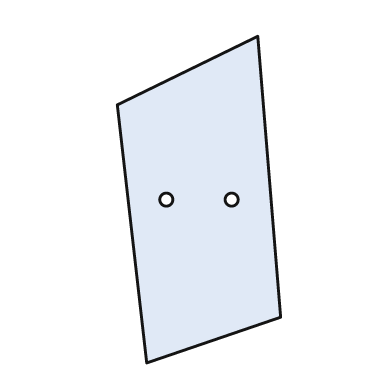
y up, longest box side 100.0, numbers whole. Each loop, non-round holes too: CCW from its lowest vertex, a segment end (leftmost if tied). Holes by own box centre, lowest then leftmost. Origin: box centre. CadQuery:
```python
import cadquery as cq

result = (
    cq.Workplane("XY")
    .moveTo(-16.0, -50.0)
    .lineTo(25.0, -36.0)
    .lineTo(18.0, 50.0)
    .lineTo(-25.0, 29.0)
    .close()
    .moveTo(-10.0, 0.0)
    .circle(2.0)
    .moveTo(10.0, 0.0)
    .circle(2.0)
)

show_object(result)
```